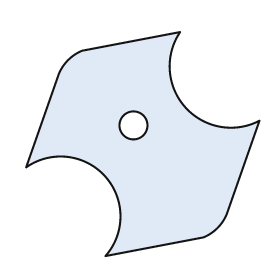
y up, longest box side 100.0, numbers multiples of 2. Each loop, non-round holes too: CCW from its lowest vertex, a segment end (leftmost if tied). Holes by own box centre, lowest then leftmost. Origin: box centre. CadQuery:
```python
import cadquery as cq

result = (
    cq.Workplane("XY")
    .moveTo(-16.0, -48.0)
    .lineTo(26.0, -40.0)
    .threePointArc((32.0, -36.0), (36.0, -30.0))
    .lineTo(50.0, 10.0)
    .threePointArc((18.0, 16.0), (16.0, 48.0))
    .lineTo(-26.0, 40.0)
    .threePointArc((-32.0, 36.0), (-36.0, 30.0))
    .lineTo(-50.0, -10.0)
    .threePointArc((-16.0, -14.0), (-16.0, -48.0))
    .close()
    .moveTo(-4.0, 8.0)
    .circle(6.0)
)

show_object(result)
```